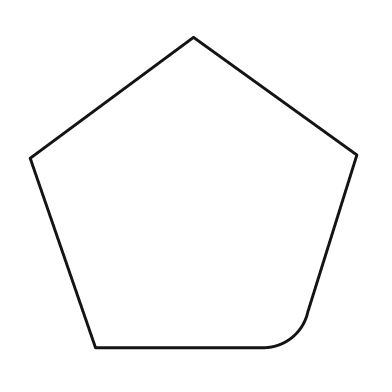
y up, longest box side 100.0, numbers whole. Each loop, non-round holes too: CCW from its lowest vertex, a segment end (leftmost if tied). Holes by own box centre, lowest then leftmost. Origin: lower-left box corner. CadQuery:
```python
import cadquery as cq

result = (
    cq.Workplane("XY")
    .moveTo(20.0, 0.0)
    .lineTo(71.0, 0.0)
    .threePointArc((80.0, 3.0), (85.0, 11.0))
    .lineTo(100.0, 59.0)
    .lineTo(50.0, 95.0)
    .lineTo(0.0, 58.0)
    .close()
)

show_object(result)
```